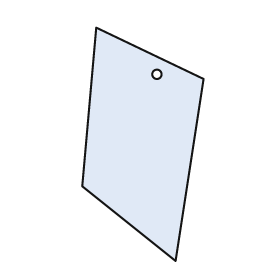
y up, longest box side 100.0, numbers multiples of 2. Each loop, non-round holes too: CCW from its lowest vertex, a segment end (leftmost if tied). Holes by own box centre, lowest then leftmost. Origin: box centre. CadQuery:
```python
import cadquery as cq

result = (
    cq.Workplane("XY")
    .moveTo(14.0, -50.0)
    .lineTo(26.0, 28.0)
    .lineTo(-20.0, 50.0)
    .lineTo(-26.0, -18.0)
    .close()
    .moveTo(6.0, 30.0)
    .circle(2.0)
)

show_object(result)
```